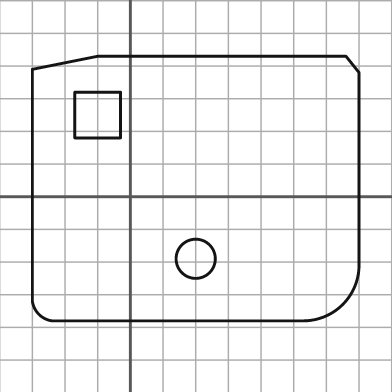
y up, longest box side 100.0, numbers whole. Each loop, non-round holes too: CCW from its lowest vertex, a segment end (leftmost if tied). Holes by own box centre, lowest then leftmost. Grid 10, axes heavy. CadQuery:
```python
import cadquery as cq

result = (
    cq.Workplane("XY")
    .moveTo(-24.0, -38.0)
    .lineTo(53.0, -38.0)
    .threePointArc((65.0, -33.0), (70.0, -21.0))
    .lineTo(70.0, 38.0)
    .lineTo(66.0, 43.0)
    .lineTo(-10.0, 43.0)
    .lineTo(-30.0, 39.0)
    .lineTo(-30.0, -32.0)
    .threePointArc((-28.0, -36.0), (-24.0, -38.0))
    .close()
    .moveTo(20.0, -19.0)
    .circle(6.0)
    .moveTo(-17.0, 18.0)
    .lineTo(-3.0, 18.0)
    .lineTo(-3.0, 32.0)
    .lineTo(-17.0, 32.0)
    .close()
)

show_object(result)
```